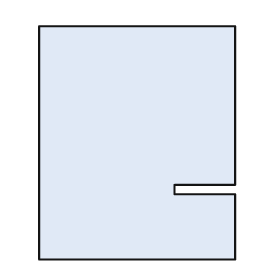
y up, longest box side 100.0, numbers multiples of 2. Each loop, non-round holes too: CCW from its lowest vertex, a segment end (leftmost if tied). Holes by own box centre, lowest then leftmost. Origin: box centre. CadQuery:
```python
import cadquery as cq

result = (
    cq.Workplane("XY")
    .moveTo(-42.0, -50.0)
    .lineTo(42.0, -50.0)
    .lineTo(42.0, -22.0)
    .lineTo(16.0, -22.0)
    .lineTo(16.0, -18.0)
    .lineTo(42.0, -18.0)
    .lineTo(42.0, 50.0)
    .lineTo(-42.0, 50.0)
    .close()
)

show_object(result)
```